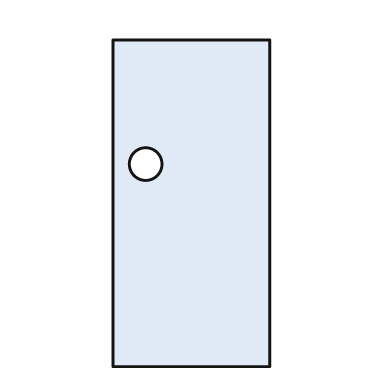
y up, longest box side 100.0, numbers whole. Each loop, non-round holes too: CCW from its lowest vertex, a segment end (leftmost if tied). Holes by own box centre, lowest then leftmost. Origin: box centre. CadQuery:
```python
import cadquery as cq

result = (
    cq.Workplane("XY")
    .moveTo(-24.0, -50.0)
    .lineTo(24.0, -50.0)
    .lineTo(24.0, 50.0)
    .lineTo(-24.0, 50.0)
    .close()
    .moveTo(-14.0, 12.0)
    .circle(5.0)
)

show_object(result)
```